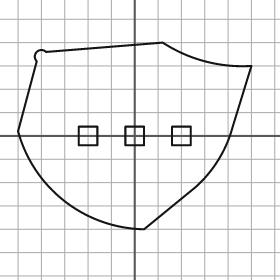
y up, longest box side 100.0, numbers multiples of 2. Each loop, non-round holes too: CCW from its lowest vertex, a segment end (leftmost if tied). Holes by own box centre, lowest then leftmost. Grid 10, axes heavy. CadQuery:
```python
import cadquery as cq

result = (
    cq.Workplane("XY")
    .moveTo(4.0, -40.0)
    .lineTo(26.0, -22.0)
    .threePointArc((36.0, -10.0), (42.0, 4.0))
    .lineTo(50.0, 30.0)
    .threePointArc((30.0, 32.0), (12.0, 40.0))
    .lineTo(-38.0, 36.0)
    .threePointArc((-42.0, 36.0), (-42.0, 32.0))
    .lineTo(-50.0, 2.0)
    .threePointArc((-30.0, -28.0), (4.0, -40.0))
    .close()
    .moveTo(-24.0, -4.0)
    .lineTo(-16.0, -4.0)
    .lineTo(-16.0, 4.0)
    .lineTo(-24.0, 4.0)
    .close()
    .moveTo(-4.0, -4.0)
    .lineTo(4.0, -4.0)
    .lineTo(4.0, 4.0)
    .lineTo(-4.0, 4.0)
    .close()
    .moveTo(16.0, -4.0)
    .lineTo(24.0, -4.0)
    .lineTo(24.0, 4.0)
    .lineTo(16.0, 4.0)
    .close()
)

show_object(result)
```